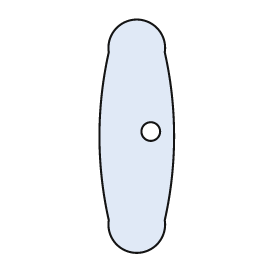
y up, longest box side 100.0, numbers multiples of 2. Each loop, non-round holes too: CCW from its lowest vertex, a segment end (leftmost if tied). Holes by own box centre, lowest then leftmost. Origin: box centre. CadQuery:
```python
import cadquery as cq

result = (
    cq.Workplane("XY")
    .moveTo(-12.0, -36.0)
    .threePointArc((0.0, -50.0), (12.0, -36.0))
    .threePointArc((16.0, 0.0), (12.0, 36.0))
    .threePointArc((0.0, 50.0), (-12.0, 36.0))
    .threePointArc((-16.0, 0.0), (-12.0, -36.0))
    .close()
    .moveTo(6.0, 2.0)
    .circle(4.0)
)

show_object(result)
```